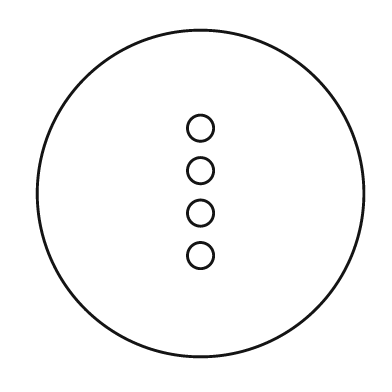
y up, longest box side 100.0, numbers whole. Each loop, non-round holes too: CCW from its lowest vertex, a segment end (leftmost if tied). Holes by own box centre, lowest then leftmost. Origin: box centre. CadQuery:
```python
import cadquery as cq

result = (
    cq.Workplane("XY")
    .moveTo(0.0, 0.0)
    .circle(50.0)
    .moveTo(0.0, -19.0)
    .circle(4.0)
    .moveTo(0.0, -6.0)
    .circle(4.0)
    .moveTo(0.0, 7.0)
    .circle(4.0)
    .moveTo(0.0, 20.0)
    .circle(4.0)
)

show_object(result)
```